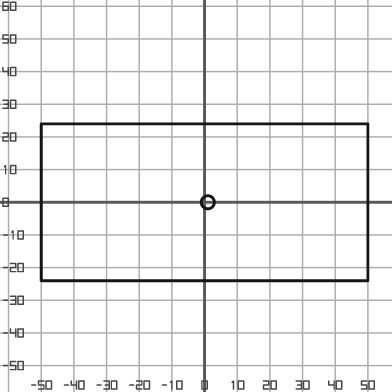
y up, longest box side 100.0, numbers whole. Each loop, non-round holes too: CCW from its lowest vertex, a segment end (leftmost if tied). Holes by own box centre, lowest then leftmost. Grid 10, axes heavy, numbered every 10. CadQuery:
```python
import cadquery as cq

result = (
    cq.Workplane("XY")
    .moveTo(-50.0, -24.0)
    .lineTo(50.0, -24.0)
    .lineTo(50.0, 24.0)
    .lineTo(-50.0, 24.0)
    .close()
    .moveTo(1.0, 0.0)
    .circle(2.0)
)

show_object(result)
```